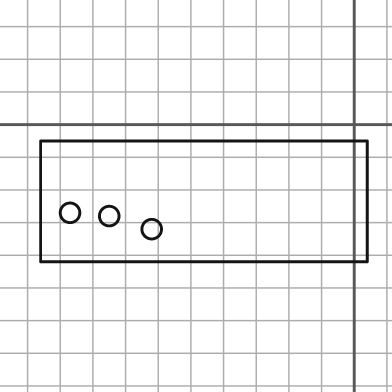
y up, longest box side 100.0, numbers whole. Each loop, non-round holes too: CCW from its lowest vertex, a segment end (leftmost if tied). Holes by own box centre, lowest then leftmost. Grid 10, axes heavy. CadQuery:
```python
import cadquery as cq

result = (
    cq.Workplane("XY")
    .moveTo(-96.0, -42.0)
    .lineTo(4.0, -42.0)
    .lineTo(4.0, -5.0)
    .lineTo(-96.0, -5.0)
    .close()
    .moveTo(-62.0, -32.0)
    .circle(3.0)
    .moveTo(-75.0, -28.0)
    .circle(3.0)
    .moveTo(-87.0, -27.0)
    .circle(3.0)
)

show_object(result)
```